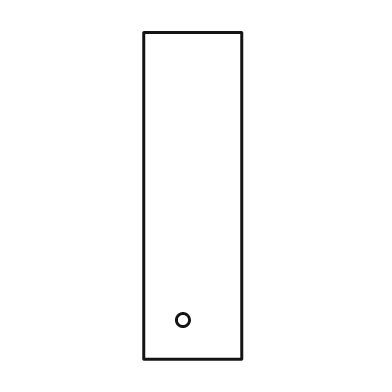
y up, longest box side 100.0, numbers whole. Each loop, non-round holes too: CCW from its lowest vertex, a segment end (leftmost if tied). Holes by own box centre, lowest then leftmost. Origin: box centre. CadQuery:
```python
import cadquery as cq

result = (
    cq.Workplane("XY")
    .moveTo(-15.0, -50.0)
    .lineTo(15.0, -50.0)
    .lineTo(15.0, 50.0)
    .lineTo(-15.0, 50.0)
    .close()
    .moveTo(-3.0, -38.0)
    .circle(2.0)
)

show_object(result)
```